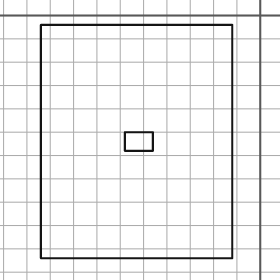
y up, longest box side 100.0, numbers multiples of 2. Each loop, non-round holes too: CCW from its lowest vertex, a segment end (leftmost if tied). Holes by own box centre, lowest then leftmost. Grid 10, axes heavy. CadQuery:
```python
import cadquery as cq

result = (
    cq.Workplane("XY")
    .moveTo(-94.0, -104.0)
    .lineTo(-12.0, -104.0)
    .lineTo(-12.0, -4.0)
    .lineTo(-94.0, -4.0)
    .close()
    .moveTo(-58.0, -58.0)
    .lineTo(-46.0, -58.0)
    .lineTo(-46.0, -50.0)
    .lineTo(-58.0, -50.0)
    .close()
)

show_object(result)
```